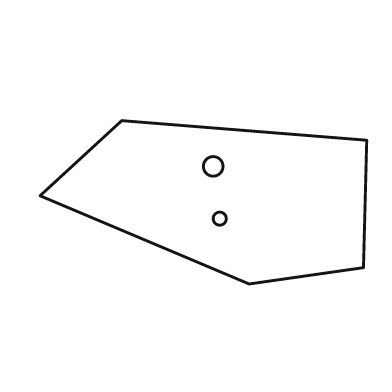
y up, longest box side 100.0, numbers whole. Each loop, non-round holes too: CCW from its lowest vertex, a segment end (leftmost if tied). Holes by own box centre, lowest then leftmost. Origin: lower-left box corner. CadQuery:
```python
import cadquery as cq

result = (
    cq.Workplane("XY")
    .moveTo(64.0, 0.0)
    .lineTo(99.0, 5.0)
    .lineTo(100.0, 44.0)
    .lineTo(25.0, 50.0)
    .lineTo(0.0, 27.0)
    .close()
    .moveTo(55.0, 20.0)
    .circle(2.0)
    .moveTo(53.0, 36.0)
    .circle(3.0)
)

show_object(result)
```